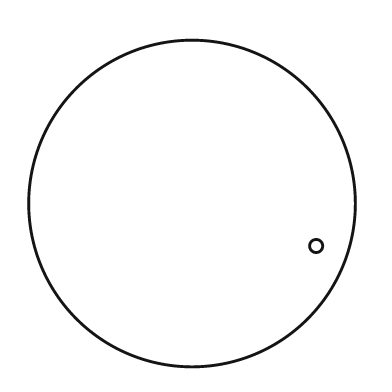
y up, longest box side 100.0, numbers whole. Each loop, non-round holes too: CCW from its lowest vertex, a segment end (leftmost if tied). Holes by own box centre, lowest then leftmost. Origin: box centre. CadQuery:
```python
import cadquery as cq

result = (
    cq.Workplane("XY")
    .moveTo(0.0, 0.0)
    .circle(50.0)
    .moveTo(38.0, -13.0)
    .circle(2.0)
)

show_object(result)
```